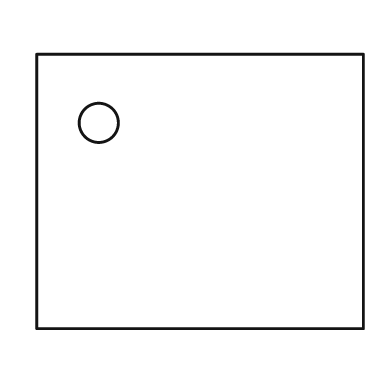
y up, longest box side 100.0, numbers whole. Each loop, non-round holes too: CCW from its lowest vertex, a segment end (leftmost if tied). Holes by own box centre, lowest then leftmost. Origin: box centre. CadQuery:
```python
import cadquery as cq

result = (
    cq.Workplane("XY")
    .moveTo(-50.0, -42.0)
    .lineTo(50.0, -42.0)
    .lineTo(50.0, 42.0)
    .lineTo(-50.0, 42.0)
    .close()
    .moveTo(-31.0, 21.0)
    .circle(6.0)
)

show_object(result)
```